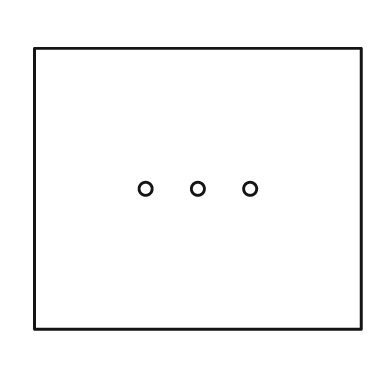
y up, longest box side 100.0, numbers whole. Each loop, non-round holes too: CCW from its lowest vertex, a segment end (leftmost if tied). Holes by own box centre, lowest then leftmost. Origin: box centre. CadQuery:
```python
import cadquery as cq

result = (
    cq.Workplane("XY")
    .moveTo(-50.0, -43.0)
    .lineTo(50.0, -43.0)
    .lineTo(50.0, 43.0)
    .lineTo(-50.0, 43.0)
    .close()
    .moveTo(-16.0, 0.0)
    .circle(2.0)
    .moveTo(0.0, 0.0)
    .circle(2.0)
    .moveTo(16.0, 0.0)
    .circle(2.0)
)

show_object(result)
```